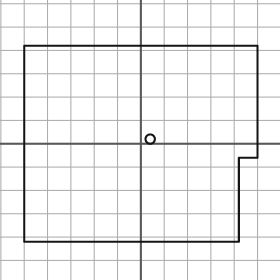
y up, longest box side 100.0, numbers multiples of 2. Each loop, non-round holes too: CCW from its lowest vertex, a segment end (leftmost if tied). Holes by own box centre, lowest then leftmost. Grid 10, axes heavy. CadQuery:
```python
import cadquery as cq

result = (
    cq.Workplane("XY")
    .moveTo(-50.0, -42.0)
    .lineTo(42.0, -42.0)
    .lineTo(42.0, -6.0)
    .lineTo(50.0, -6.0)
    .lineTo(50.0, 42.0)
    .lineTo(-50.0, 42.0)
    .close()
    .moveTo(4.0, 2.0)
    .circle(2.0)
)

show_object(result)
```